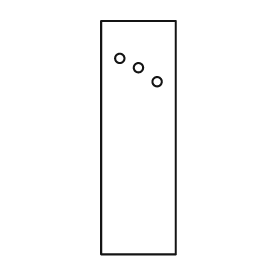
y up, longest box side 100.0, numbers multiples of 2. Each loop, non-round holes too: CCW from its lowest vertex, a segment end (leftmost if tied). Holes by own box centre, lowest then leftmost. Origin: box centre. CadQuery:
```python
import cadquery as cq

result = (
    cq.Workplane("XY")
    .moveTo(-16.0, -50.0)
    .lineTo(16.0, -50.0)
    .lineTo(16.0, 50.0)
    .lineTo(-16.0, 50.0)
    .close()
    .moveTo(8.0, 24.0)
    .circle(2.0)
    .moveTo(0.0, 30.0)
    .circle(2.0)
    .moveTo(-8.0, 34.0)
    .circle(2.0)
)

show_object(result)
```